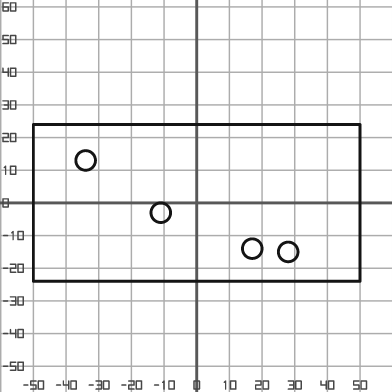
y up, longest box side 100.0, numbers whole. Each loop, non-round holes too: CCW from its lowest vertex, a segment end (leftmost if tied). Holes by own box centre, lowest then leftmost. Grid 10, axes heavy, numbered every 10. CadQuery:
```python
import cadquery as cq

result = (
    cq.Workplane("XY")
    .moveTo(-50.0, -24.0)
    .lineTo(50.0, -24.0)
    .lineTo(50.0, 24.0)
    .lineTo(-50.0, 24.0)
    .close()
    .moveTo(28.0, -15.0)
    .circle(3.0)
    .moveTo(17.0, -14.0)
    .circle(3.0)
    .moveTo(-11.0, -3.0)
    .circle(3.0)
    .moveTo(-34.0, 13.0)
    .circle(3.0)
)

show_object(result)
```